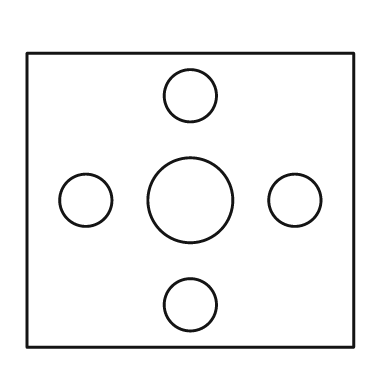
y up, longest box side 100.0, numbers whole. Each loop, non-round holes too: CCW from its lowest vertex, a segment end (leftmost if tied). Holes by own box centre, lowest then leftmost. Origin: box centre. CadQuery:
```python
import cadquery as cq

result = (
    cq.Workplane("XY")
    .moveTo(-50.0, -45.0)
    .lineTo(50.0, -45.0)
    .lineTo(50.0, 45.0)
    .lineTo(-50.0, 45.0)
    .close()
    .moveTo(0.0, -32.0)
    .circle(8.0)
    .moveTo(-32.0, 0.0)
    .circle(8.0)
    .moveTo(0.0, 0.0)
    .circle(13.0)
    .moveTo(32.0, 0.0)
    .circle(8.0)
    .moveTo(0.0, 32.0)
    .circle(8.0)
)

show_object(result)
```